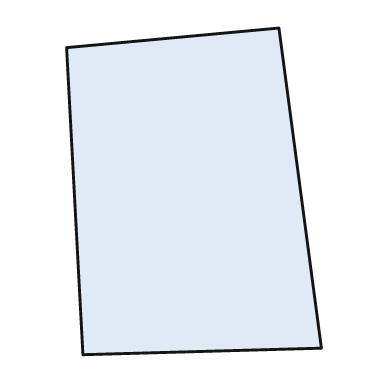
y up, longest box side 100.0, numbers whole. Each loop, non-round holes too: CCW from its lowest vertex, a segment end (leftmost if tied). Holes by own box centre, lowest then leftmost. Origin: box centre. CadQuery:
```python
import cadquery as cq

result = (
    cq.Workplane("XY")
    .moveTo(-34.0, -50.0)
    .lineTo(39.0, -48.0)
    .lineTo(26.0, 50.0)
    .lineTo(-39.0, 44.0)
    .close()
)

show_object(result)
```